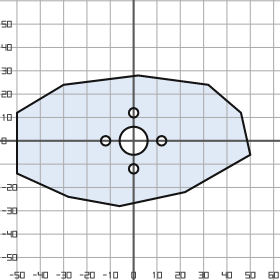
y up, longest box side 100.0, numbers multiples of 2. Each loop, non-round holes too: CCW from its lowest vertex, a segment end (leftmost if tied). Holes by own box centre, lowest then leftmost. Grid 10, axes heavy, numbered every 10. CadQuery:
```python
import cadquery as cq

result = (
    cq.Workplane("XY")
    .moveTo(-6.0, -28.0)
    .lineTo(22.0, -22.0)
    .lineTo(50.0, -6.0)
    .lineTo(46.0, 12.0)
    .lineTo(32.0, 24.0)
    .lineTo(2.0, 28.0)
    .lineTo(-30.0, 24.0)
    .lineTo(-50.0, 12.0)
    .lineTo(-50.0, -14.0)
    .lineTo(-28.0, -24.0)
    .close()
    .moveTo(0.0, -12.0)
    .circle(2.0)
    .moveTo(-12.0, 0.0)
    .circle(2.0)
    .moveTo(0.0, 0.0)
    .circle(6.0)
    .moveTo(12.0, 0.0)
    .circle(2.0)
    .moveTo(0.0, 12.0)
    .circle(2.0)
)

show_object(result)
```